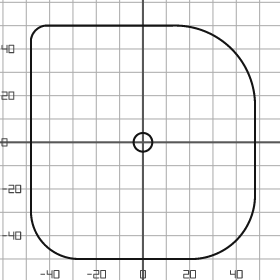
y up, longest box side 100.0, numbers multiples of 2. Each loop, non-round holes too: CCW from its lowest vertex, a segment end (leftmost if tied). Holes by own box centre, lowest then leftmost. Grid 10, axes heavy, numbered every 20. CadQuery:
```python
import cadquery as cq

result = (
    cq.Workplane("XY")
    .moveTo(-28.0, -50.0)
    .lineTo(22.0, -50.0)
    .threePointArc((40.0, -42.0), (48.0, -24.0))
    .lineTo(48.0, 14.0)
    .threePointArc((38.0, 40.0), (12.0, 50.0))
    .lineTo(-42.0, 50.0)
    .threePointArc((-46.0, 48.0), (-48.0, 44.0))
    .lineTo(-48.0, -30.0)
    .threePointArc((-42.0, -44.0), (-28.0, -50.0))
    .close()
    .moveTo(0.0, 0.0)
    .circle(4.0)
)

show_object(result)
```